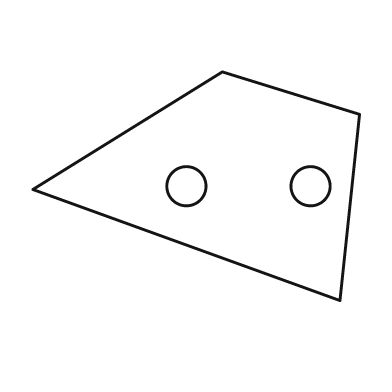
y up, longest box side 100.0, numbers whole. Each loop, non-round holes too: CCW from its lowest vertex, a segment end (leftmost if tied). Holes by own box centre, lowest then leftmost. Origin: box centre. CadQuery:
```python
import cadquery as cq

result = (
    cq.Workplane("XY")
    .moveTo(44.0, -35.0)
    .lineTo(50.0, 22.0)
    .lineTo(8.0, 35.0)
    .lineTo(-50.0, -1.0)
    .close()
    .moveTo(-3.0, 0.0)
    .circle(6.0)
    .moveTo(35.0, 0.0)
    .circle(6.0)
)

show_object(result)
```